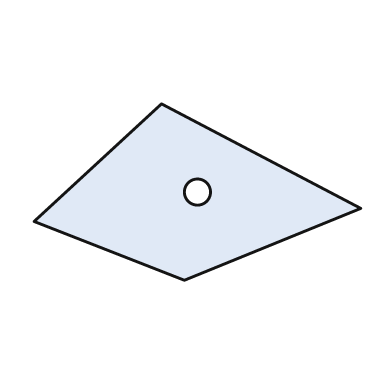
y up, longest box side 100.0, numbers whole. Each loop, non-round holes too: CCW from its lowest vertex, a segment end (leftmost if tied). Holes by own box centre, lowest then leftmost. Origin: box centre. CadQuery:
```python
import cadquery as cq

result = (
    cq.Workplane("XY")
    .moveTo(-4.0, -27.0)
    .lineTo(50.0, -5.0)
    .lineTo(-11.0, 27.0)
    .lineTo(-50.0, -9.0)
    .close()
    .moveTo(0.0, 0.0)
    .circle(4.0)
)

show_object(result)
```